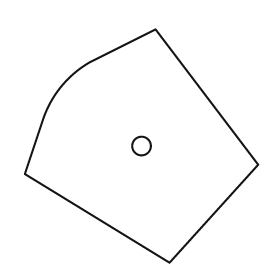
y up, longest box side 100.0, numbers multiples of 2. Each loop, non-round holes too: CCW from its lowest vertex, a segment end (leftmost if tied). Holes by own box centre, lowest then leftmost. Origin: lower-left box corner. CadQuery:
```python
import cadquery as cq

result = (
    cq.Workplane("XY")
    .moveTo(62.0, 0.0)
    .lineTo(100.0, 42.0)
    .lineTo(56.0, 100.0)
    .lineTo(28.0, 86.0)
    .threePointArc((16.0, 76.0), (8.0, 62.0))
    .lineTo(0.0, 38.0)
    .close()
    .moveTo(50.0, 50.0)
    .circle(4.0)
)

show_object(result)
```